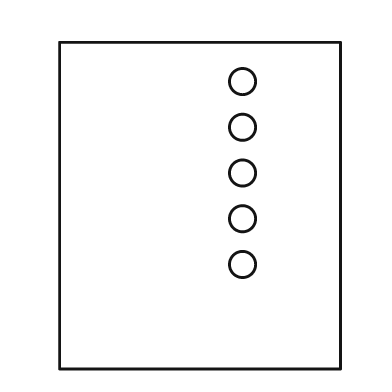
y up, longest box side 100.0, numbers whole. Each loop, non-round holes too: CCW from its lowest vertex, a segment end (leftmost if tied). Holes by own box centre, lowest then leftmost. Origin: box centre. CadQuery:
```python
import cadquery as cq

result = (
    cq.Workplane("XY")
    .moveTo(-43.0, -50.0)
    .lineTo(43.0, -50.0)
    .lineTo(43.0, 50.0)
    .lineTo(-43.0, 50.0)
    .close()
    .moveTo(13.0, -18.0)
    .circle(4.0)
    .moveTo(13.0, -4.0)
    .circle(4.0)
    .moveTo(13.0, 10.0)
    .circle(4.0)
    .moveTo(13.0, 24.0)
    .circle(4.0)
    .moveTo(13.0, 38.0)
    .circle(4.0)
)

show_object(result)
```